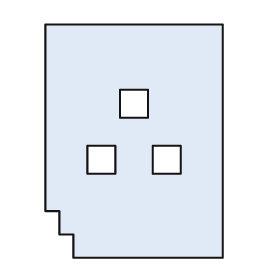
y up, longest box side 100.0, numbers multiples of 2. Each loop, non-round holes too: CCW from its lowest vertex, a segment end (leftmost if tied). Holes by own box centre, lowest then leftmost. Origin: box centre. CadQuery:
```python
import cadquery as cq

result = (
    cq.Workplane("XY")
    .moveTo(-26.0, -50.0)
    .lineTo(38.0, -50.0)
    .lineTo(38.0, 50.0)
    .lineTo(-38.0, 50.0)
    .lineTo(-38.0, -30.0)
    .lineTo(-32.0, -30.0)
    .lineTo(-32.0, -40.0)
    .lineTo(-26.0, -40.0)
    .close()
    .moveTo(-20.0, -14.0)
    .lineTo(-8.0, -14.0)
    .lineTo(-8.0, -2.0)
    .lineTo(-20.0, -2.0)
    .close()
    .moveTo(8.0, -14.0)
    .lineTo(20.0, -14.0)
    .lineTo(20.0, -2.0)
    .lineTo(8.0, -2.0)
    .close()
    .moveTo(-6.0, 10.0)
    .lineTo(6.0, 10.0)
    .lineTo(6.0, 22.0)
    .lineTo(-6.0, 22.0)
    .close()
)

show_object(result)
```